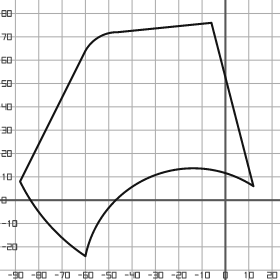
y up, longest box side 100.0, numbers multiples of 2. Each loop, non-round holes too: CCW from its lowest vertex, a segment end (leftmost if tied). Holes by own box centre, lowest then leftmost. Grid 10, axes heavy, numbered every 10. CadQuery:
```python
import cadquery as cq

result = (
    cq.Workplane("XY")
    .moveTo(-60.0, -24.0)
    .threePointArc((-32.0, 10.0), (12.0, 6.0))
    .lineTo(-6.0, 76.0)
    .lineTo(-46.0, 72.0)
    .threePointArc((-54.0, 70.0), (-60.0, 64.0))
    .lineTo(-88.0, 8.0)
    .threePointArc((-76.0, -10.0), (-60.0, -24.0))
    .close()
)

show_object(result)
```